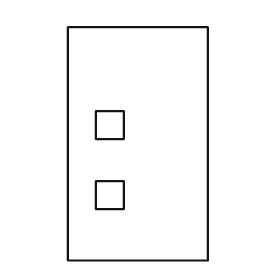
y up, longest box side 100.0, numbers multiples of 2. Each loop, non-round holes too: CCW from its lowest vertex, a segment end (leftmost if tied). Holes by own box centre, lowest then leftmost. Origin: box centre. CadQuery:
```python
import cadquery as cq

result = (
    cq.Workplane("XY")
    .moveTo(-30.0, -50.0)
    .lineTo(30.0, -50.0)
    .lineTo(30.0, 50.0)
    .lineTo(-30.0, 50.0)
    .close()
    .moveTo(-18.0, -28.0)
    .lineTo(-6.0, -28.0)
    .lineTo(-6.0, -16.0)
    .lineTo(-18.0, -16.0)
    .close()
    .moveTo(-18.0, 2.0)
    .lineTo(-6.0, 2.0)
    .lineTo(-6.0, 14.0)
    .lineTo(-18.0, 14.0)
    .close()
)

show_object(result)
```